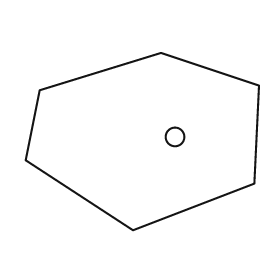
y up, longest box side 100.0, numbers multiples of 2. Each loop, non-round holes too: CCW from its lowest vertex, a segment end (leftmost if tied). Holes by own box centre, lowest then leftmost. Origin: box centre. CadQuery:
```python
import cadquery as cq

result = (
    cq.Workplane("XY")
    .moveTo(-4.0, -38.0)
    .lineTo(48.0, -18.0)
    .lineTo(50.0, 24.0)
    .lineTo(8.0, 38.0)
    .lineTo(-44.0, 22.0)
    .lineTo(-50.0, -8.0)
    .close()
    .moveTo(14.0, 2.0)
    .circle(4.0)
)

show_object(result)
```